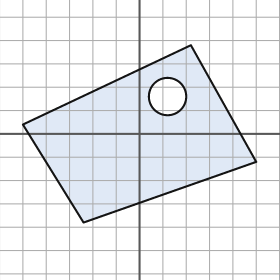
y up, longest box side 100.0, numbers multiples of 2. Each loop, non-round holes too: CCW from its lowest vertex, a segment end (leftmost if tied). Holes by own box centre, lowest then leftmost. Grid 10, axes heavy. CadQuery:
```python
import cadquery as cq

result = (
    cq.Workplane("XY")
    .moveTo(-24.0, -38.0)
    .lineTo(50.0, -12.0)
    .lineTo(22.0, 38.0)
    .lineTo(-50.0, 4.0)
    .close()
    .moveTo(12.0, 16.0)
    .circle(8.0)
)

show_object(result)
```